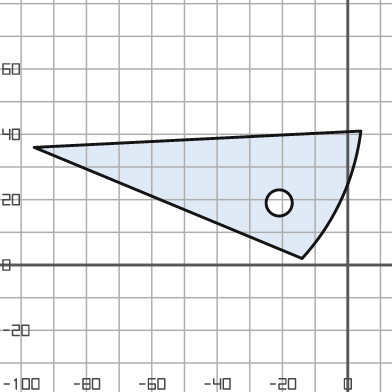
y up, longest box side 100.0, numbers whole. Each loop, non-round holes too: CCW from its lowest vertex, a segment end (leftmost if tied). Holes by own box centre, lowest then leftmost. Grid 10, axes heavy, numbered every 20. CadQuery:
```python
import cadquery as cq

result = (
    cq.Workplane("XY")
    .moveTo(-14.0, 2.0)
    .threePointArc((-2.0, 20.0), (4.0, 41.0))
    .lineTo(-96.0, 36.0)
    .close()
    .moveTo(-21.0, 19.0)
    .circle(4.0)
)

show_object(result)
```